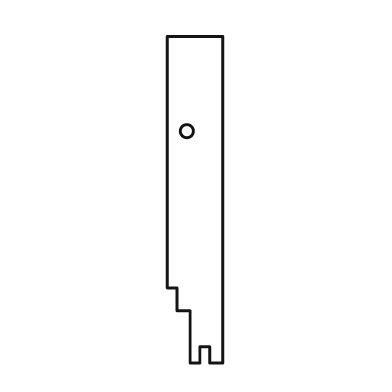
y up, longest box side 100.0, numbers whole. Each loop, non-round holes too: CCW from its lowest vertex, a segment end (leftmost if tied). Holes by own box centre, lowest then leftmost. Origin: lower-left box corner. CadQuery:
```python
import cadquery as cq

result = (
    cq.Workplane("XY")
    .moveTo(7.0, 0.0)
    .lineTo(10.0, 0.0)
    .lineTo(10.0, 5.0)
    .lineTo(13.0, 5.0)
    .lineTo(13.0, 0.0)
    .lineTo(17.0, 0.0)
    .lineTo(17.0, 100.0)
    .lineTo(0.0, 100.0)
    .lineTo(0.0, 23.0)
    .lineTo(3.0, 23.0)
    .lineTo(3.0, 16.0)
    .lineTo(7.0, 16.0)
    .close()
    .moveTo(6.0, 71.0)
    .circle(2.0)
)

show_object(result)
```